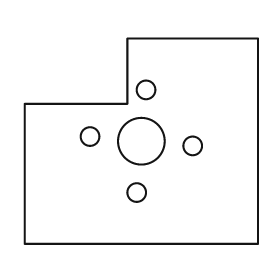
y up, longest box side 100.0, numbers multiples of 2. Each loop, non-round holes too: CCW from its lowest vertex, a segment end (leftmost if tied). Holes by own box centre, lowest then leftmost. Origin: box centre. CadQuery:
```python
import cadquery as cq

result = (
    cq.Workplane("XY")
    .moveTo(-50.0, -44.0)
    .lineTo(50.0, -44.0)
    .lineTo(50.0, 44.0)
    .lineTo(-6.0, 44.0)
    .lineTo(-6.0, 16.0)
    .lineTo(-50.0, 16.0)
    .close()
    .moveTo(-2.0, -22.0)
    .circle(4.0)
    .moveTo(22.0, -2.0)
    .circle(4.0)
    .moveTo(0.0, 0.0)
    .circle(10.0)
    .moveTo(-22.0, 2.0)
    .circle(4.0)
    .moveTo(2.0, 22.0)
    .circle(4.0)
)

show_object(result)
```